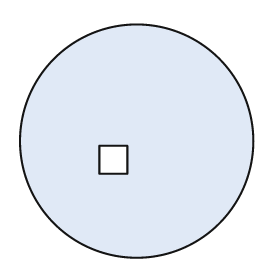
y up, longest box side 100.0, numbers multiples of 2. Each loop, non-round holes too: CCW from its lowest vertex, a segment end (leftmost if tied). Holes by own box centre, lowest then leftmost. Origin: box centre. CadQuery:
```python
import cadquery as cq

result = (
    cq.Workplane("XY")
    .moveTo(0.0, 0.0)
    .circle(50.0)
    .moveTo(-16.0, -14.0)
    .lineTo(-4.0, -14.0)
    .lineTo(-4.0, -2.0)
    .lineTo(-16.0, -2.0)
    .close()
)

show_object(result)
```